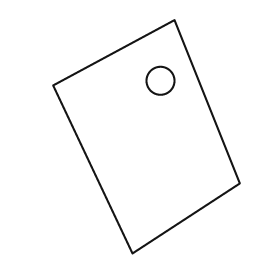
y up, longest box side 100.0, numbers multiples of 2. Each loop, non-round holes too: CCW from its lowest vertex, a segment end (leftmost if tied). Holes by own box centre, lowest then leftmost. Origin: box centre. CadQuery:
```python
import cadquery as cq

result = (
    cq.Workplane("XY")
    .moveTo(-6.0, -50.0)
    .lineTo(40.0, -20.0)
    .lineTo(12.0, 50.0)
    .lineTo(-40.0, 22.0)
    .close()
    .moveTo(6.0, 24.0)
    .circle(6.0)
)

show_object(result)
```